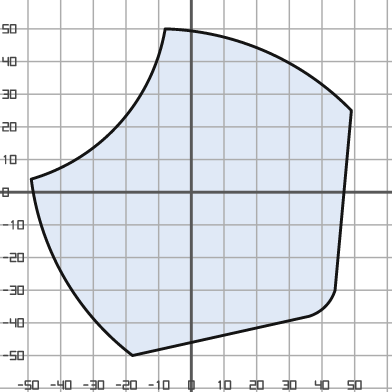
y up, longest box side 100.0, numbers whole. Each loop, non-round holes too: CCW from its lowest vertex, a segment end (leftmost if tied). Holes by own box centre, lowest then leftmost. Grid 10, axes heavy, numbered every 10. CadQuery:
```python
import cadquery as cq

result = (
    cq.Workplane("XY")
    .moveTo(-18.0, -50.0)
    .lineTo(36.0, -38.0)
    .threePointArc((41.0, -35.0), (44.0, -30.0))
    .lineTo(49.0, 25.0)
    .threePointArc((23.0, 43.0), (-8.0, 50.0))
    .threePointArc((-22.0, 21.0), (-49.0, 4.0))
    .threePointArc((-39.0, -26.0), (-18.0, -50.0))
    .close()
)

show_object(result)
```